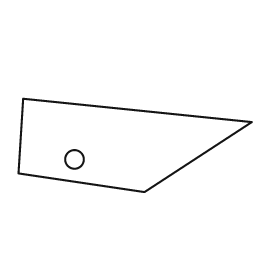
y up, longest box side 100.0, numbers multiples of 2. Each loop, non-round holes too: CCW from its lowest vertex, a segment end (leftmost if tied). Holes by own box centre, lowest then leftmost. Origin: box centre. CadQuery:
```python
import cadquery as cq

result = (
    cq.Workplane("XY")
    .moveTo(4.0, -20.0)
    .lineTo(50.0, 10.0)
    .lineTo(-48.0, 20.0)
    .lineTo(-50.0, -12.0)
    .close()
    .moveTo(-26.0, -6.0)
    .circle(4.0)
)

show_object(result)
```